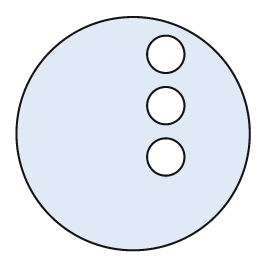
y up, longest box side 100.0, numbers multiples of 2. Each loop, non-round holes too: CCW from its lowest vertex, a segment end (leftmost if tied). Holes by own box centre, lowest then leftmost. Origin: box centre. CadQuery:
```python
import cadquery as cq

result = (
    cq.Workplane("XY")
    .moveTo(0.0, 0.0)
    .circle(50.0)
    .moveTo(14.0, -10.0)
    .circle(8.0)
    .moveTo(14.0, 12.0)
    .circle(8.0)
    .moveTo(14.0, 34.0)
    .circle(8.0)
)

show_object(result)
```